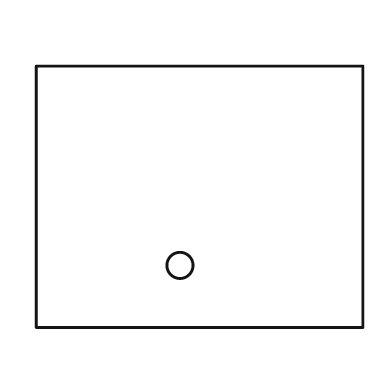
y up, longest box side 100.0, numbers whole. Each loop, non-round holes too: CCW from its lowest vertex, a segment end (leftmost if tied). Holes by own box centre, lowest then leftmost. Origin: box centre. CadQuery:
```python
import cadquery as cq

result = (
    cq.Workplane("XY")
    .moveTo(-50.0, -40.0)
    .lineTo(50.0, -40.0)
    .lineTo(50.0, 40.0)
    .lineTo(-50.0, 40.0)
    .close()
    .moveTo(-6.0, -21.0)
    .circle(4.0)
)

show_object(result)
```